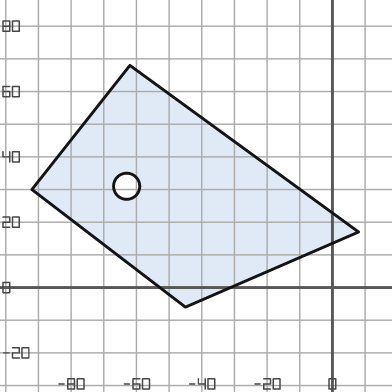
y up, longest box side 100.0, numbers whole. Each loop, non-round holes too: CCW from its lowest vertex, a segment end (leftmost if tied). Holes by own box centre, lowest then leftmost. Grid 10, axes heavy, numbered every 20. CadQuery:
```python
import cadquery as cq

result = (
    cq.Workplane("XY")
    .moveTo(-45.0, -6.0)
    .lineTo(8.0, 17.0)
    .lineTo(-62.0, 68.0)
    .lineTo(-92.0, 30.0)
    .close()
    .moveTo(-63.0, 31.0)
    .circle(4.0)
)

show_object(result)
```